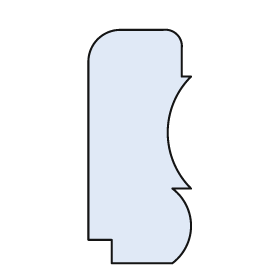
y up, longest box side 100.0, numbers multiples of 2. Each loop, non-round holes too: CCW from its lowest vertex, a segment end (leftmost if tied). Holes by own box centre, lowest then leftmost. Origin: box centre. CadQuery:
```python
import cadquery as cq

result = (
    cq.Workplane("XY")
    .moveTo(-12.0, -50.0)
    .lineTo(14.0, -50.0)
    .threePointArc((22.0, -34.0), (14.0, -18.0))
    .lineTo(22.0, -18.0)
    .threePointArc((12.0, 6.0), (22.0, 30.0))
    .lineTo(18.0, 30.0)
    .lineTo(18.0, 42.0)
    .threePointArc((16.0, 48.0), (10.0, 50.0))
    .lineTo(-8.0, 50.0)
    .threePointArc((-18.0, 46.0), (-22.0, 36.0))
    .lineTo(-22.0, -40.0)
    .lineTo(-12.0, -40.0)
    .close()
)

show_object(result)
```